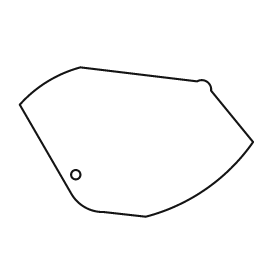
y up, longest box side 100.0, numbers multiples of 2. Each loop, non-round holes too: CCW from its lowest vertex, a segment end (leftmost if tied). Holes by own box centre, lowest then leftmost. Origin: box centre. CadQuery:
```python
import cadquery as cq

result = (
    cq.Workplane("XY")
    .moveTo(4.0, -32.0)
    .threePointArc((30.0, -20.0), (50.0, 0.0))
    .lineTo(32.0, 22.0)
    .threePointArc((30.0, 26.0), (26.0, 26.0))
    .lineTo(-24.0, 32.0)
    .threePointArc((-38.0, 26.0), (-50.0, 16.0))
    .lineTo(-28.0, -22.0)
    .threePointArc((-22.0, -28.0), (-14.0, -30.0))
    .close()
    .moveTo(-26.0, -14.0)
    .circle(2.0)
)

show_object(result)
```